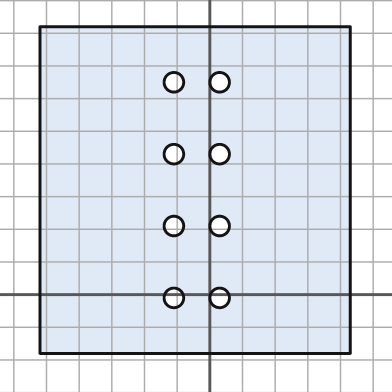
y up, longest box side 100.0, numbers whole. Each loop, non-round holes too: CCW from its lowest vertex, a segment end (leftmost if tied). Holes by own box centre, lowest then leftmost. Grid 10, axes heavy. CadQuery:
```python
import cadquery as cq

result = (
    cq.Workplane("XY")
    .moveTo(-52.0, -18.0)
    .lineTo(43.0, -18.0)
    .lineTo(43.0, 82.0)
    .lineTo(-52.0, 82.0)
    .close()
    .moveTo(-11.0, -1.0)
    .circle(3.0)
    .moveTo(3.0, -1.0)
    .circle(3.0)
    .moveTo(-11.0, 21.0)
    .circle(3.0)
    .moveTo(3.0, 21.0)
    .circle(3.0)
    .moveTo(-11.0, 43.0)
    .circle(3.0)
    .moveTo(3.0, 43.0)
    .circle(3.0)
    .moveTo(-11.0, 65.0)
    .circle(3.0)
    .moveTo(3.0, 65.0)
    .circle(3.0)
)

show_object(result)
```